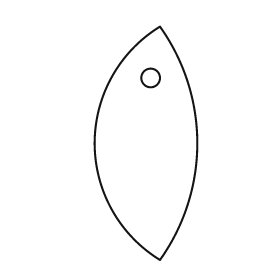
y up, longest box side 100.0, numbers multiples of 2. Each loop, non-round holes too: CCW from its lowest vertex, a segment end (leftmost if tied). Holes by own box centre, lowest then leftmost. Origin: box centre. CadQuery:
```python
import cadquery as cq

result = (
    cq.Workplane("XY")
    .moveTo(6.0, -50.0)
    .threePointArc((22.0, 0.0), (6.0, 50.0))
    .threePointArc((-22.0, 0.0), (6.0, -50.0))
    .close()
    .moveTo(2.0, 28.0)
    .circle(4.0)
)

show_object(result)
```